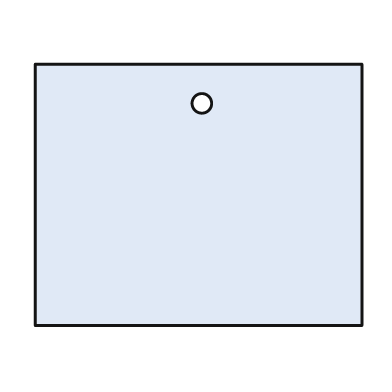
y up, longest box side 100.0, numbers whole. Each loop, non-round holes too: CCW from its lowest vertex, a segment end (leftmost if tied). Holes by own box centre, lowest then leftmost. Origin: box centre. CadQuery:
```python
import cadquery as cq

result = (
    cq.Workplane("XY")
    .moveTo(-50.0, -40.0)
    .lineTo(50.0, -40.0)
    .lineTo(50.0, 40.0)
    .lineTo(-50.0, 40.0)
    .close()
    .moveTo(1.0, 28.0)
    .circle(3.0)
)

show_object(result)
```